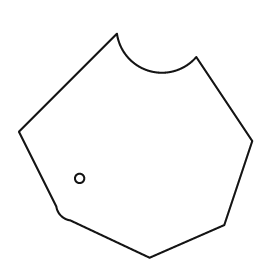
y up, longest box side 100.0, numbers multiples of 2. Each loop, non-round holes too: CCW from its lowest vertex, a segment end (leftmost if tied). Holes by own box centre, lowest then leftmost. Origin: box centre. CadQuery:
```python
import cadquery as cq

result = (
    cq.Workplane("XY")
    .moveTo(6.0, -48.0)
    .lineTo(38.0, -34.0)
    .lineTo(50.0, 2.0)
    .lineTo(26.0, 38.0)
    .threePointArc((6.0, 32.0), (-8.0, 48.0))
    .lineTo(-50.0, 6.0)
    .lineTo(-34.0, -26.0)
    .threePointArc((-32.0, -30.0), (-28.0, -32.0))
    .close()
    .moveTo(-24.0, -14.0)
    .circle(2.0)
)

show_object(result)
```